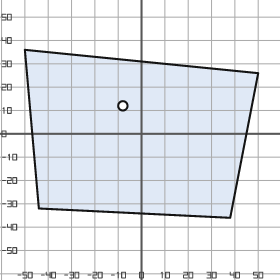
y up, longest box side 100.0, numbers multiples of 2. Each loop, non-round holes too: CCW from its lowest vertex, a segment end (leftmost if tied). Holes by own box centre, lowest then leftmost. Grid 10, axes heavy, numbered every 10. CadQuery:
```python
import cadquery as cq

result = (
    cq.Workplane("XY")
    .moveTo(38.0, -36.0)
    .lineTo(50.0, 26.0)
    .lineTo(-50.0, 36.0)
    .lineTo(-44.0, -32.0)
    .close()
    .moveTo(-8.0, 12.0)
    .circle(2.0)
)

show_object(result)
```